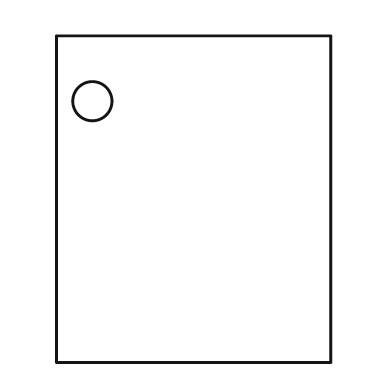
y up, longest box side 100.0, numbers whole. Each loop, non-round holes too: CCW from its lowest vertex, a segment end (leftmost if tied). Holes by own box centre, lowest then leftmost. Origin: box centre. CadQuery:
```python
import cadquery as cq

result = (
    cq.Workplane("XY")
    .moveTo(-42.0, -50.0)
    .lineTo(42.0, -50.0)
    .lineTo(42.0, 50.0)
    .lineTo(-42.0, 50.0)
    .close()
    .moveTo(-31.0, 30.0)
    .circle(6.0)
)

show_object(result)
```